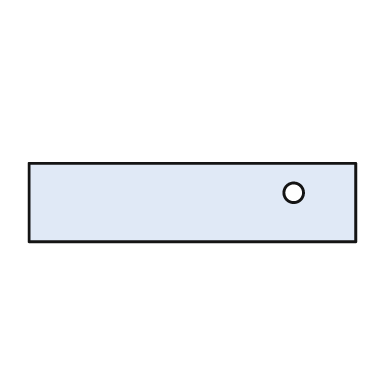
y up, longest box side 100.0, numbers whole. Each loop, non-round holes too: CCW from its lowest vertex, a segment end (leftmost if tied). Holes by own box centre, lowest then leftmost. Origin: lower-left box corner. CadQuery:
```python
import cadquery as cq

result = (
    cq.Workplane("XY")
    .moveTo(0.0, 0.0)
    .lineTo(100.0, 0.0)
    .lineTo(100.0, 24.0)
    .lineTo(0.0, 24.0)
    .close()
    .moveTo(81.0, 15.0)
    .circle(3.0)
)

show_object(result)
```